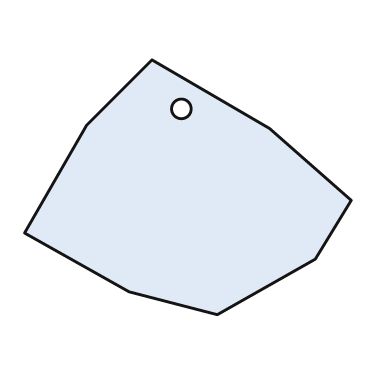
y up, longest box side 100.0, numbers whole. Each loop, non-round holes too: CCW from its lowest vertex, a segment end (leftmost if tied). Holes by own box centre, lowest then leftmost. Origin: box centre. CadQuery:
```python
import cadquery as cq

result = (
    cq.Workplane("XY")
    .moveTo(9.0, -39.0)
    .lineTo(39.0, -22.0)
    .lineTo(50.0, -4.0)
    .lineTo(25.0, 18.0)
    .lineTo(-11.0, 39.0)
    .lineTo(-31.0, 19.0)
    .lineTo(-50.0, -14.0)
    .lineTo(-18.0, -32.0)
    .close()
    .moveTo(-2.0, 24.0)
    .circle(3.0)
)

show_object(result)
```